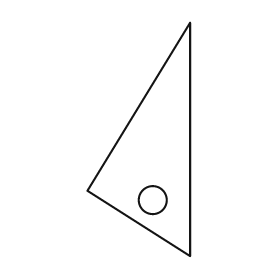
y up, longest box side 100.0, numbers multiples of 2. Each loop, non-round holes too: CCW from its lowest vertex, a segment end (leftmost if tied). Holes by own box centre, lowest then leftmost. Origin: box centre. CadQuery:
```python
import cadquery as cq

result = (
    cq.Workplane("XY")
    .moveTo(22.0, -50.0)
    .lineTo(22.0, 50.0)
    .lineTo(-22.0, -22.0)
    .close()
    .moveTo(6.0, -26.0)
    .circle(6.0)
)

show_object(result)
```